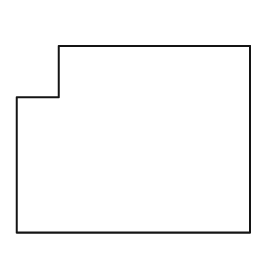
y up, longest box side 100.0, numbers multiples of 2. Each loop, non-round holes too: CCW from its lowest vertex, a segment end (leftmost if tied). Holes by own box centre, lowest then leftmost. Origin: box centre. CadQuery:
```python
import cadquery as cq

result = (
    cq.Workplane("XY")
    .moveTo(-50.0, -40.0)
    .lineTo(50.0, -40.0)
    .lineTo(50.0, 40.0)
    .lineTo(-32.0, 40.0)
    .lineTo(-32.0, 18.0)
    .lineTo(-50.0, 18.0)
    .close()
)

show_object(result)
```